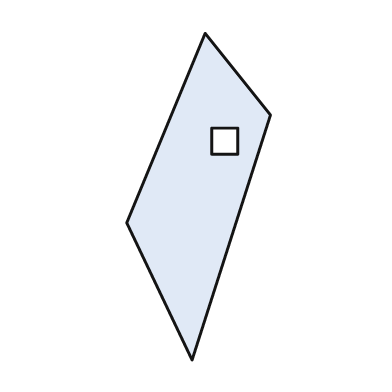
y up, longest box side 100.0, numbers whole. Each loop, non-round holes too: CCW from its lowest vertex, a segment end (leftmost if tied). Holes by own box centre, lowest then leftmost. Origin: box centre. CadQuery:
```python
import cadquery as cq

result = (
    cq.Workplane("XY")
    .moveTo(-2.0, -50.0)
    .lineTo(22.0, 25.0)
    .lineTo(2.0, 50.0)
    .lineTo(-22.0, -8.0)
    .close()
    .moveTo(4.0, 13.0)
    .lineTo(12.0, 13.0)
    .lineTo(12.0, 21.0)
    .lineTo(4.0, 21.0)
    .close()
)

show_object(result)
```